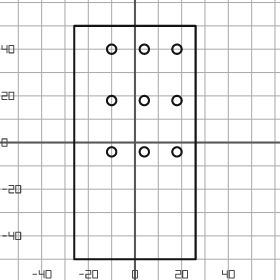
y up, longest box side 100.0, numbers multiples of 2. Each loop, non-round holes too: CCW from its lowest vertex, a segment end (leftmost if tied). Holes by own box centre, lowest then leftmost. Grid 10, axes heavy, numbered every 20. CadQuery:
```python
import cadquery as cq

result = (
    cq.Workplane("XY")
    .moveTo(-26.0, -50.0)
    .lineTo(26.0, -50.0)
    .lineTo(26.0, 50.0)
    .lineTo(-26.0, 50.0)
    .close()
    .moveTo(-10.0, -4.0)
    .circle(2.0)
    .moveTo(4.0, -4.0)
    .circle(2.0)
    .moveTo(18.0, -4.0)
    .circle(2.0)
    .moveTo(-10.0, 18.0)
    .circle(2.0)
    .moveTo(4.0, 18.0)
    .circle(2.0)
    .moveTo(18.0, 18.0)
    .circle(2.0)
    .moveTo(-10.0, 40.0)
    .circle(2.0)
    .moveTo(4.0, 40.0)
    .circle(2.0)
    .moveTo(18.0, 40.0)
    .circle(2.0)
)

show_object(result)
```